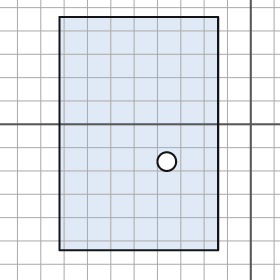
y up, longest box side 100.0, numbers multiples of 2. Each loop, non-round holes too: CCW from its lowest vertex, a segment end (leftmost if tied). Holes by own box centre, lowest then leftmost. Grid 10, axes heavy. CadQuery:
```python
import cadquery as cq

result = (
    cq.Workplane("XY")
    .moveTo(-82.0, -54.0)
    .lineTo(-14.0, -54.0)
    .lineTo(-14.0, 46.0)
    .lineTo(-82.0, 46.0)
    .close()
    .moveTo(-36.0, -16.0)
    .circle(4.0)
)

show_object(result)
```